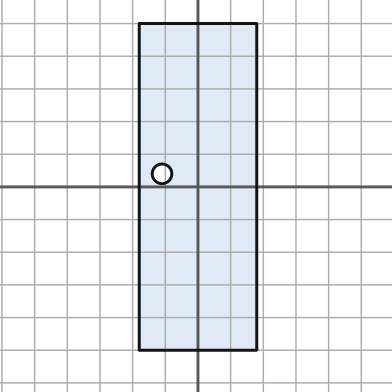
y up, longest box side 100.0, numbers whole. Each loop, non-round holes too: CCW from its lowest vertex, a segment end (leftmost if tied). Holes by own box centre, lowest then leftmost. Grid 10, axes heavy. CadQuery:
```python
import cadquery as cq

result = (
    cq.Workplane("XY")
    .moveTo(-18.0, -50.0)
    .lineTo(18.0, -50.0)
    .lineTo(18.0, 50.0)
    .lineTo(-18.0, 50.0)
    .close()
    .moveTo(-11.0, 4.0)
    .circle(3.0)
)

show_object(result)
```